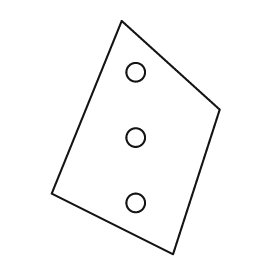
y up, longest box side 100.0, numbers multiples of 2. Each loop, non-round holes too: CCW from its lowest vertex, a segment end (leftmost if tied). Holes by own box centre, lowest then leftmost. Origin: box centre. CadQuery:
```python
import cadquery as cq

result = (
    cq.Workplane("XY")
    .moveTo(16.0, -50.0)
    .lineTo(36.0, 12.0)
    .lineTo(-6.0, 50.0)
    .lineTo(-36.0, -24.0)
    .close()
    .moveTo(0.0, -28.0)
    .circle(4.0)
    .moveTo(0.0, 0.0)
    .circle(4.0)
    .moveTo(0.0, 28.0)
    .circle(4.0)
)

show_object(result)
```